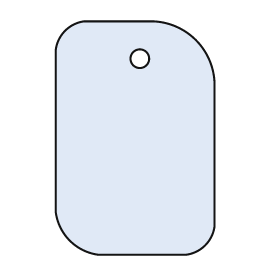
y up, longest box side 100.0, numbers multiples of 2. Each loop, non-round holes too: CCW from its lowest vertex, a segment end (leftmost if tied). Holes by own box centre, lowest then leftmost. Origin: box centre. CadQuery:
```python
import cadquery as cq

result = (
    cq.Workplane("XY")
    .moveTo(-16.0, -50.0)
    .lineTo(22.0, -50.0)
    .threePointArc((30.0, -46.0), (34.0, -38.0))
    .lineTo(34.0, 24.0)
    .threePointArc((26.0, 42.0), (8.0, 50.0))
    .lineTo(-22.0, 50.0)
    .threePointArc((-30.0, 46.0), (-34.0, 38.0))
    .lineTo(-34.0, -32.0)
    .threePointArc((-28.0, -44.0), (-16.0, -50.0))
    .close()
    .moveTo(2.0, 34.0)
    .circle(4.0)
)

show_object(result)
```